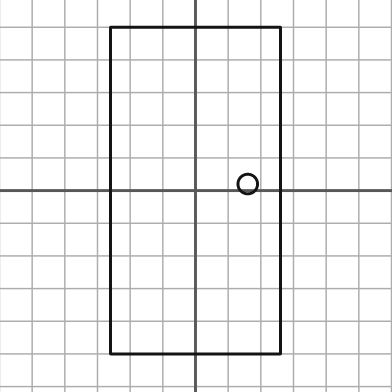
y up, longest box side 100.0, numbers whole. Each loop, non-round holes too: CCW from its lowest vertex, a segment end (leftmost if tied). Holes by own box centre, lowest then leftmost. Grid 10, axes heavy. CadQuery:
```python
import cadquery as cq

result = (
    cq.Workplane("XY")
    .moveTo(-26.0, -50.0)
    .lineTo(26.0, -50.0)
    .lineTo(26.0, 50.0)
    .lineTo(-26.0, 50.0)
    .close()
    .moveTo(16.0, 2.0)
    .circle(3.0)
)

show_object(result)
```